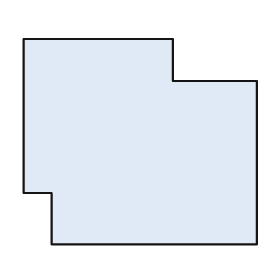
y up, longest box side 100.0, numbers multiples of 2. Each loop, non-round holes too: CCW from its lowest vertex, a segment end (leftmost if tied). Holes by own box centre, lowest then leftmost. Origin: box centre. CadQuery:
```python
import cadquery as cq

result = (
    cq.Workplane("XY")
    .moveTo(-38.0, -44.0)
    .lineTo(50.0, -44.0)
    .lineTo(50.0, 26.0)
    .lineTo(14.0, 26.0)
    .lineTo(14.0, 44.0)
    .lineTo(-50.0, 44.0)
    .lineTo(-50.0, -22.0)
    .lineTo(-38.0, -22.0)
    .close()
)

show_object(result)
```